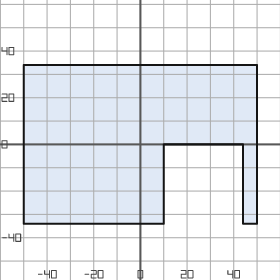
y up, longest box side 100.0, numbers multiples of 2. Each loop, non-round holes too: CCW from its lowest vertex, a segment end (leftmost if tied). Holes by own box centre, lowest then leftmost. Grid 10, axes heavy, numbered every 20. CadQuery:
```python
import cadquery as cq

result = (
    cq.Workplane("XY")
    .moveTo(-50.0, -34.0)
    .lineTo(10.0, -34.0)
    .lineTo(10.0, 0.0)
    .lineTo(44.0, 0.0)
    .lineTo(44.0, -34.0)
    .lineTo(50.0, -34.0)
    .lineTo(50.0, 34.0)
    .lineTo(-50.0, 34.0)
    .close()
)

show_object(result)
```